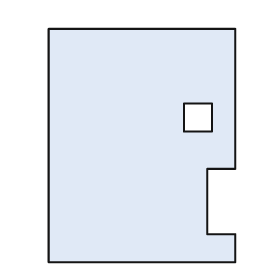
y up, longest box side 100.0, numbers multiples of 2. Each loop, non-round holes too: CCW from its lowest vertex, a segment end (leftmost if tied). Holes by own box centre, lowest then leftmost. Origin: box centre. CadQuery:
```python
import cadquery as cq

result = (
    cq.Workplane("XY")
    .moveTo(-40.0, -50.0)
    .lineTo(40.0, -50.0)
    .lineTo(40.0, -38.0)
    .lineTo(28.0, -38.0)
    .lineTo(28.0, -10.0)
    .lineTo(40.0, -10.0)
    .lineTo(40.0, 50.0)
    .lineTo(-40.0, 50.0)
    .close()
    .moveTo(18.0, 6.0)
    .lineTo(30.0, 6.0)
    .lineTo(30.0, 18.0)
    .lineTo(18.0, 18.0)
    .close()
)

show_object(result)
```